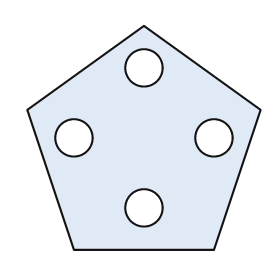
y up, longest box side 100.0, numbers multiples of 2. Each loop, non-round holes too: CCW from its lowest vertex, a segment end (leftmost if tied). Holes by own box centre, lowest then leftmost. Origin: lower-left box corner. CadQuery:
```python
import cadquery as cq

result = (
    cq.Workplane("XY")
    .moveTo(20.0, 0.0)
    .lineTo(80.0, 0.0)
    .lineTo(100.0, 60.0)
    .lineTo(50.0, 96.0)
    .lineTo(0.0, 60.0)
    .close()
    .moveTo(50.0, 18.0)
    .circle(8.0)
    .moveTo(20.0, 48.0)
    .circle(8.0)
    .moveTo(80.0, 48.0)
    .circle(8.0)
    .moveTo(50.0, 78.0)
    .circle(8.0)
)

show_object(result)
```